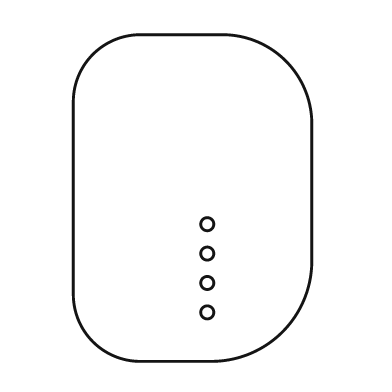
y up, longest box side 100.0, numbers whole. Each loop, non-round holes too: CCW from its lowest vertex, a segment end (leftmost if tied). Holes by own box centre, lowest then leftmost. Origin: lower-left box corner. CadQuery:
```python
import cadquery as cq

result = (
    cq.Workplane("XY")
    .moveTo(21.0, 0.0)
    .lineTo(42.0, 0.0)
    .threePointArc((64.0, 9.0), (73.0, 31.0))
    .lineTo(73.0, 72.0)
    .threePointArc((65.0, 92.0), (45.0, 100.0))
    .lineTo(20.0, 100.0)
    .threePointArc((6.0, 94.0), (0.0, 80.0))
    .lineTo(0.0, 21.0)
    .threePointArc((6.0, 6.0), (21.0, 0.0))
    .close()
    .moveTo(41.0, 15.0)
    .circle(2.0)
    .moveTo(41.0, 24.0)
    .circle(2.0)
    .moveTo(41.0, 33.0)
    .circle(2.0)
    .moveTo(41.0, 42.0)
    .circle(2.0)
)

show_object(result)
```